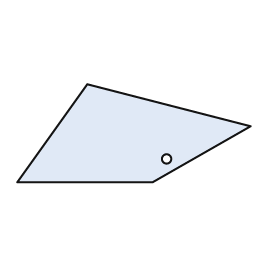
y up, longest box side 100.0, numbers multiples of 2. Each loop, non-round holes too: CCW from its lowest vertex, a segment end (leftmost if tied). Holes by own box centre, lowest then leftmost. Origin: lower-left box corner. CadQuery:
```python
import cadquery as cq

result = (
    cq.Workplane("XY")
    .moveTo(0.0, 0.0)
    .lineTo(58.0, 0.0)
    .lineTo(100.0, 24.0)
    .lineTo(30.0, 42.0)
    .close()
    .moveTo(64.0, 10.0)
    .circle(2.0)
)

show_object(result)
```